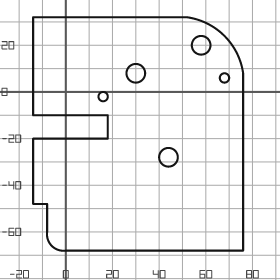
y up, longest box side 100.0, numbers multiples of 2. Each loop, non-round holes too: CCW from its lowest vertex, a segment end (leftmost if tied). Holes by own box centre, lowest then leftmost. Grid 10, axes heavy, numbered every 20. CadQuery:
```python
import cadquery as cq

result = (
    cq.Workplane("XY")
    .moveTo(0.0, -68.0)
    .lineTo(76.0, -68.0)
    .lineTo(76.0, 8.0)
    .threePointArc((68.0, 24.0), (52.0, 32.0))
    .lineTo(-14.0, 32.0)
    .lineTo(-14.0, -10.0)
    .lineTo(18.0, -10.0)
    .lineTo(18.0, -20.0)
    .lineTo(-14.0, -20.0)
    .lineTo(-14.0, -48.0)
    .lineTo(-8.0, -48.0)
    .lineTo(-8.0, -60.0)
    .threePointArc((-6.0, -66.0), (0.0, -68.0))
    .close()
    .moveTo(44.0, -28.0)
    .circle(4.0)
    .moveTo(16.0, -2.0)
    .circle(2.0)
    .moveTo(68.0, 6.0)
    .circle(2.0)
    .moveTo(30.0, 8.0)
    .circle(4.0)
    .moveTo(58.0, 20.0)
    .circle(4.0)
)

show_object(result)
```